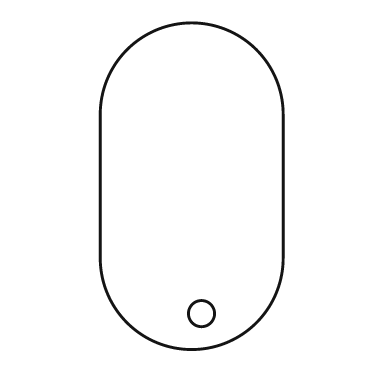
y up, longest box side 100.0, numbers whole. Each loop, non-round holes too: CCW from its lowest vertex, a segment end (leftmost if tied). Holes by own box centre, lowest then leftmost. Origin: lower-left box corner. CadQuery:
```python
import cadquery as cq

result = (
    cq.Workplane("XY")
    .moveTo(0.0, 28.0)
    .threePointArc((28.0, 0.0), (56.0, 28.0))
    .lineTo(56.0, 72.0)
    .threePointArc((28.0, 100.0), (0.0, 72.0))
    .close()
    .moveTo(31.0, 11.0)
    .circle(4.0)
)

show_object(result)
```